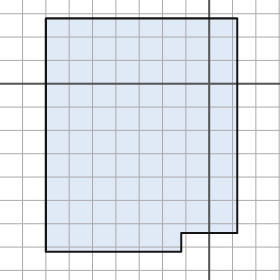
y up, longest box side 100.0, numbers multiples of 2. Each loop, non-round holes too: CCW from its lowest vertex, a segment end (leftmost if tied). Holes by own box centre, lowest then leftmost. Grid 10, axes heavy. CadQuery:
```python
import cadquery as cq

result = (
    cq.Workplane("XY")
    .moveTo(-70.0, -72.0)
    .lineTo(-12.0, -72.0)
    .lineTo(-12.0, -64.0)
    .lineTo(12.0, -64.0)
    .lineTo(12.0, 28.0)
    .lineTo(-70.0, 28.0)
    .close()
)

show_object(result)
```